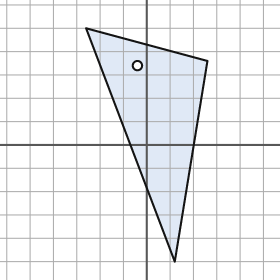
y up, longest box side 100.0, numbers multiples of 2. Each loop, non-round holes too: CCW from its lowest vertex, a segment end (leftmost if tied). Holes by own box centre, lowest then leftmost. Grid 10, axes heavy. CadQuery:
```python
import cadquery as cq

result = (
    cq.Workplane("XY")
    .moveTo(12.0, -50.0)
    .lineTo(26.0, 36.0)
    .lineTo(-26.0, 50.0)
    .close()
    .moveTo(-4.0, 34.0)
    .circle(2.0)
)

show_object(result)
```